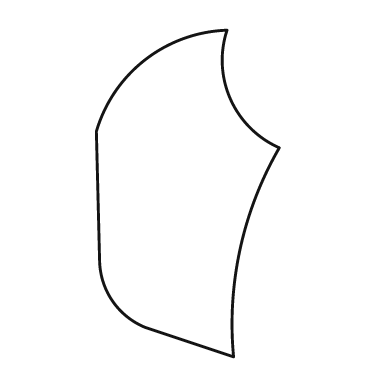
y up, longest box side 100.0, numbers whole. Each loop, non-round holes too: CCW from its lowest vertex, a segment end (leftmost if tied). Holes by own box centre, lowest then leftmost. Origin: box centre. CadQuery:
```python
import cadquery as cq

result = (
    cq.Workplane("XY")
    .moveTo(14.0, -50.0)
    .threePointArc((16.0, -17.0), (28.0, 14.0))
    .threePointArc((13.0, 29.0), (12.0, 50.0))
    .threePointArc((-13.0, 41.0), (-28.0, 19.0))
    .lineTo(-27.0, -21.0)
    .threePointArc((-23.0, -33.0), (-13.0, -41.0))
    .close()
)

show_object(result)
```